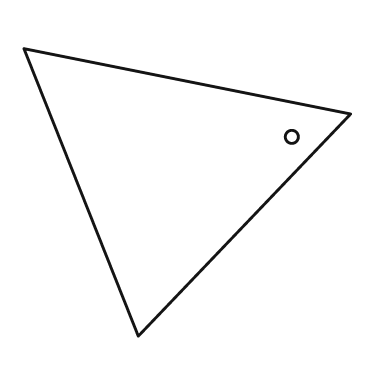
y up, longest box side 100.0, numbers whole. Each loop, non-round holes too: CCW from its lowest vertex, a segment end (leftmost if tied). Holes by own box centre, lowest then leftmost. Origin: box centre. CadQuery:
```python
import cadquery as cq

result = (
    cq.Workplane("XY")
    .moveTo(-15.0, -44.0)
    .lineTo(50.0, 24.0)
    .lineTo(-50.0, 44.0)
    .close()
    .moveTo(32.0, 17.0)
    .circle(2.0)
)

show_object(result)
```